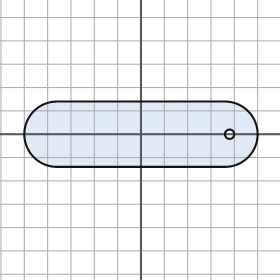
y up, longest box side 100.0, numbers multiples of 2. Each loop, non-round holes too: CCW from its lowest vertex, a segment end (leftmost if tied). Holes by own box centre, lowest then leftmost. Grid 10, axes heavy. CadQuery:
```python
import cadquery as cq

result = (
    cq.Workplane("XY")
    .moveTo(-36.0, -14.0)
    .lineTo(36.0, -14.0)
    .threePointArc((50.0, 0.0), (36.0, 14.0))
    .lineTo(-36.0, 14.0)
    .threePointArc((-50.0, 0.0), (-36.0, -14.0))
    .close()
    .moveTo(38.0, 0.0)
    .circle(2.0)
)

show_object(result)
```